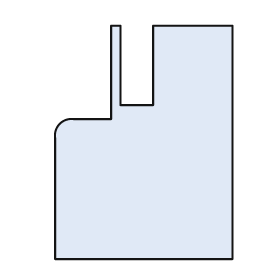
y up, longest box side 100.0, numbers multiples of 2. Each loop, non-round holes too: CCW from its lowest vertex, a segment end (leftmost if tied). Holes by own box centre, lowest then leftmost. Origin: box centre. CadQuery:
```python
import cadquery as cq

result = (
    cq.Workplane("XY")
    .moveTo(-38.0, -50.0)
    .lineTo(38.0, -50.0)
    .lineTo(38.0, 50.0)
    .lineTo(4.0, 50.0)
    .lineTo(4.0, 16.0)
    .lineTo(-10.0, 16.0)
    .lineTo(-10.0, 50.0)
    .lineTo(-14.0, 50.0)
    .lineTo(-14.0, 10.0)
    .lineTo(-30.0, 10.0)
    .threePointArc((-36.0, 8.0), (-38.0, 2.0))
    .close()
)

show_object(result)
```